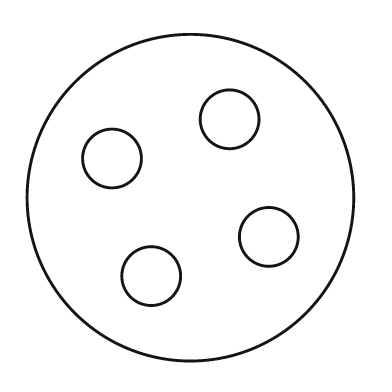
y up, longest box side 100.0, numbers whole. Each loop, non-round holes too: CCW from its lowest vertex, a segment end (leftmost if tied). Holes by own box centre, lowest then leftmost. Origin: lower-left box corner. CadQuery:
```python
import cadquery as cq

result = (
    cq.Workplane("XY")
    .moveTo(50.0, 50.0)
    .circle(50.0)
    .moveTo(38.0, 26.0)
    .circle(9.0)
    .moveTo(74.0, 38.0)
    .circle(9.0)
    .moveTo(26.0, 62.0)
    .circle(9.0)
    .moveTo(62.0, 74.0)
    .circle(9.0)
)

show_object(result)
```